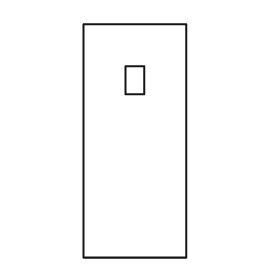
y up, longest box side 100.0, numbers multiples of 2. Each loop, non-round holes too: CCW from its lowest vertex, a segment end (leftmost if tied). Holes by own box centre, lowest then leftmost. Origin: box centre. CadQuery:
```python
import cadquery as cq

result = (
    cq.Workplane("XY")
    .moveTo(-22.0, -50.0)
    .lineTo(22.0, -50.0)
    .lineTo(22.0, 50.0)
    .lineTo(-22.0, 50.0)
    .close()
    .moveTo(-4.0, 20.0)
    .lineTo(4.0, 20.0)
    .lineTo(4.0, 32.0)
    .lineTo(-4.0, 32.0)
    .close()
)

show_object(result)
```